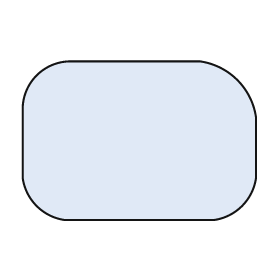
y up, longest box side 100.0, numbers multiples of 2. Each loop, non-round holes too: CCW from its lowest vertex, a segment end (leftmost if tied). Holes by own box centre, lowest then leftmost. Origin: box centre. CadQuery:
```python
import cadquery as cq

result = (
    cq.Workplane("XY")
    .moveTo(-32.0, -34.0)
    .lineTo(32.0, -34.0)
    .threePointArc((44.0, -28.0), (50.0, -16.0))
    .lineTo(50.0, 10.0)
    .threePointArc((42.0, 26.0), (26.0, 34.0))
    .lineTo(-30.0, 34.0)
    .threePointArc((-44.0, 28.0), (-50.0, 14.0))
    .lineTo(-50.0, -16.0)
    .threePointArc((-44.0, -28.0), (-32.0, -34.0))
    .close()
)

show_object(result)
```